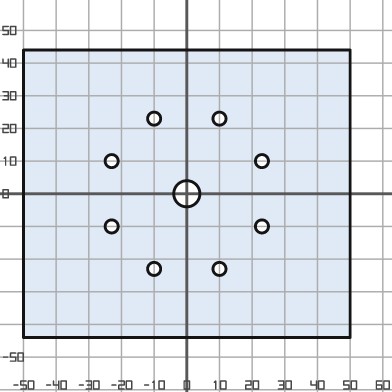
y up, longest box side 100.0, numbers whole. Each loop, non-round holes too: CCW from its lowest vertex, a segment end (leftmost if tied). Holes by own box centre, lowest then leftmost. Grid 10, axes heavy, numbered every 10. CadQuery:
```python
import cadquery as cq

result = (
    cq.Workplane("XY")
    .moveTo(-50.0, -44.0)
    .lineTo(50.0, -44.0)
    .lineTo(50.0, 44.0)
    .lineTo(-50.0, 44.0)
    .close()
    .moveTo(-10.0, -23.0)
    .circle(2.0)
    .moveTo(10.0, -23.0)
    .circle(2.0)
    .moveTo(-23.0, -10.0)
    .circle(2.0)
    .moveTo(23.0, -10.0)
    .circle(2.0)
    .moveTo(0.0, 0.0)
    .circle(4.0)
    .moveTo(-23.0, 10.0)
    .circle(2.0)
    .moveTo(23.0, 10.0)
    .circle(2.0)
    .moveTo(-10.0, 23.0)
    .circle(2.0)
    .moveTo(10.0, 23.0)
    .circle(2.0)
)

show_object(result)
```